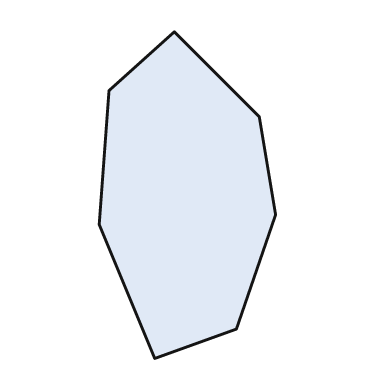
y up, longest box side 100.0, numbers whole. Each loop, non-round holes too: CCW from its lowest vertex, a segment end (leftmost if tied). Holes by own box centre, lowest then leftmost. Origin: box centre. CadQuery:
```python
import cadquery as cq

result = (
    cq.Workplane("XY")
    .moveTo(-10.0, -50.0)
    .lineTo(15.0, -41.0)
    .lineTo(27.0, -6.0)
    .lineTo(22.0, 24.0)
    .lineTo(-4.0, 50.0)
    .lineTo(-24.0, 32.0)
    .lineTo(-27.0, -9.0)
    .close()
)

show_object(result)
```